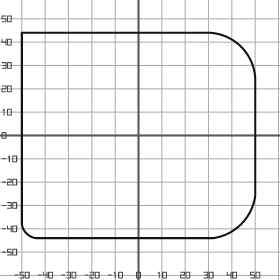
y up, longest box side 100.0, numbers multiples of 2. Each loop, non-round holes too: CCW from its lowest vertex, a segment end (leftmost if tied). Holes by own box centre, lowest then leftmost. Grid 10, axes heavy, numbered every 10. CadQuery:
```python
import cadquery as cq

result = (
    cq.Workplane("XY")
    .moveTo(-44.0, -44.0)
    .lineTo(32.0, -44.0)
    .threePointArc((44.0, -38.0), (50.0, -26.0))
    .lineTo(50.0, 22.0)
    .threePointArc((44.0, 38.0), (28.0, 44.0))
    .lineTo(-50.0, 44.0)
    .lineTo(-50.0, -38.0)
    .threePointArc((-48.0, -42.0), (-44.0, -44.0))
    .close()
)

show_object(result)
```